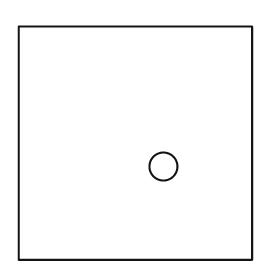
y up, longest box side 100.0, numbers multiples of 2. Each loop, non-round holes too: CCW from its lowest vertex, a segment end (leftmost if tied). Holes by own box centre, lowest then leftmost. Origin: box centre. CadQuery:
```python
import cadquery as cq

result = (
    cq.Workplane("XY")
    .moveTo(-50.0, -50.0)
    .lineTo(50.0, -50.0)
    .lineTo(50.0, 50.0)
    .lineTo(-50.0, 50.0)
    .close()
    .moveTo(12.0, -10.0)
    .circle(6.0)
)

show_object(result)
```